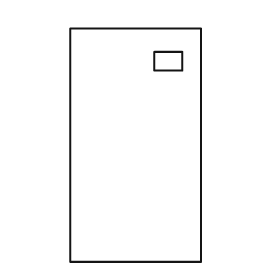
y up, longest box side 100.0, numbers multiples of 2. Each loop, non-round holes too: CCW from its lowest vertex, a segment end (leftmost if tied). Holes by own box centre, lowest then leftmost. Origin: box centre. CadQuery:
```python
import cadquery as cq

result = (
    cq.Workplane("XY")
    .moveTo(-28.0, -50.0)
    .lineTo(28.0, -50.0)
    .lineTo(28.0, 50.0)
    .lineTo(-28.0, 50.0)
    .close()
    .moveTo(8.0, 32.0)
    .lineTo(20.0, 32.0)
    .lineTo(20.0, 40.0)
    .lineTo(8.0, 40.0)
    .close()
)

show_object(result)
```